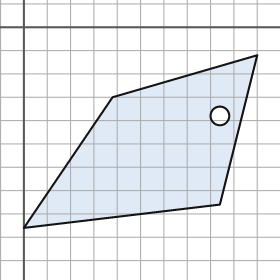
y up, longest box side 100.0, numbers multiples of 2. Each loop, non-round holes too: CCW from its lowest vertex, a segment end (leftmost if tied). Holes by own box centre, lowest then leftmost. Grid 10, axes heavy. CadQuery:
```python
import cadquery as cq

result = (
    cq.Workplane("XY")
    .moveTo(0.0, -86.0)
    .lineTo(84.0, -76.0)
    .lineTo(100.0, -12.0)
    .lineTo(38.0, -30.0)
    .close()
    .moveTo(84.0, -38.0)
    .circle(4.0)
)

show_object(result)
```